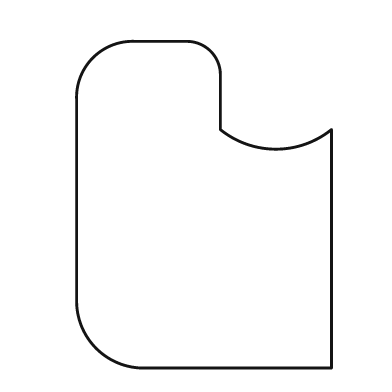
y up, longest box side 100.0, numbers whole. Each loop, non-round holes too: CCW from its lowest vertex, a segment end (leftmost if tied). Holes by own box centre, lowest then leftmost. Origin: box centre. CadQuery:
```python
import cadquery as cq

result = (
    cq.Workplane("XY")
    .moveTo(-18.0, -50.0)
    .lineTo(39.0, -50.0)
    .lineTo(39.0, 23.0)
    .threePointArc((22.0, 17.0), (5.0, 23.0))
    .lineTo(5.0, 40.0)
    .threePointArc((2.0, 47.0), (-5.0, 50.0))
    .lineTo(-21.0, 50.0)
    .threePointArc((-34.0, 45.0), (-39.0, 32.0))
    .lineTo(-39.0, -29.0)
    .threePointArc((-33.0, -44.0), (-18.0, -50.0))
    .close()
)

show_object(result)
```